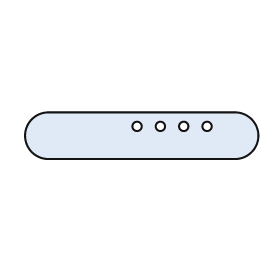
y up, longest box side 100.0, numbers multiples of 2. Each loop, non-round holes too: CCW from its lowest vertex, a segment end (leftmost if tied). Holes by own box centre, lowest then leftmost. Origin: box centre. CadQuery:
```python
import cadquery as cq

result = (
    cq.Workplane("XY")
    .moveTo(-40.0, -10.0)
    .lineTo(40.0, -10.0)
    .threePointArc((50.0, 0.0), (40.0, 10.0))
    .lineTo(-40.0, 10.0)
    .threePointArc((-50.0, 0.0), (-40.0, -10.0))
    .close()
    .moveTo(-2.0, 4.0)
    .circle(2.0)
    .moveTo(8.0, 4.0)
    .circle(2.0)
    .moveTo(18.0, 4.0)
    .circle(2.0)
    .moveTo(28.0, 4.0)
    .circle(2.0)
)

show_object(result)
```